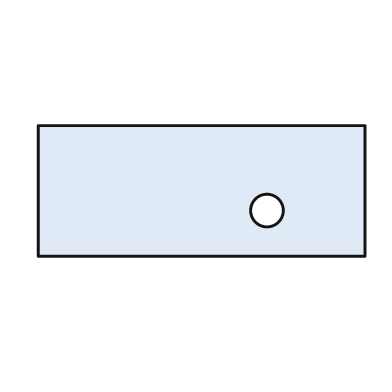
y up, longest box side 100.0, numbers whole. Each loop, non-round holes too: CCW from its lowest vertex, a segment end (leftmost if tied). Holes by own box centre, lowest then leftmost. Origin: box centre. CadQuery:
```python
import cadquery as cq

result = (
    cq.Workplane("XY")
    .moveTo(-50.0, -20.0)
    .lineTo(50.0, -20.0)
    .lineTo(50.0, 20.0)
    .lineTo(-50.0, 20.0)
    .close()
    .moveTo(20.0, -6.0)
    .circle(5.0)
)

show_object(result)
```